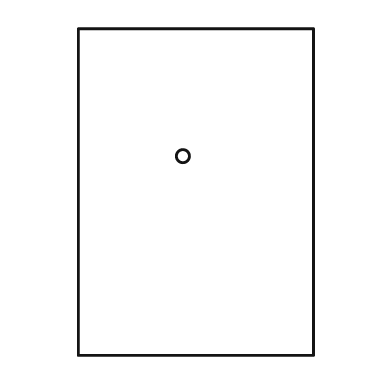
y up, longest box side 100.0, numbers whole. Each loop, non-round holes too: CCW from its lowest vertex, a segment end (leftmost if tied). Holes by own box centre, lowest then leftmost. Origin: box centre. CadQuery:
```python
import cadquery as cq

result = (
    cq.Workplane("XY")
    .moveTo(-36.0, -50.0)
    .lineTo(36.0, -50.0)
    .lineTo(36.0, 50.0)
    .lineTo(-36.0, 50.0)
    .close()
    .moveTo(-4.0, 11.0)
    .circle(2.0)
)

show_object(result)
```